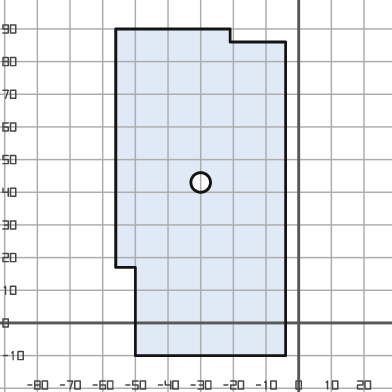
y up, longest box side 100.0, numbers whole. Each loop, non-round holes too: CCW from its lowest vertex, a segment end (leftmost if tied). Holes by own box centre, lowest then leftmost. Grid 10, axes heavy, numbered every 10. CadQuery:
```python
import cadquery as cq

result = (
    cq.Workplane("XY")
    .moveTo(-50.0, -10.0)
    .lineTo(-4.0, -10.0)
    .lineTo(-4.0, 86.0)
    .lineTo(-21.0, 86.0)
    .lineTo(-21.0, 90.0)
    .lineTo(-56.0, 90.0)
    .lineTo(-56.0, 17.0)
    .lineTo(-50.0, 17.0)
    .close()
    .moveTo(-30.0, 43.0)
    .circle(3.0)
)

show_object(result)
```